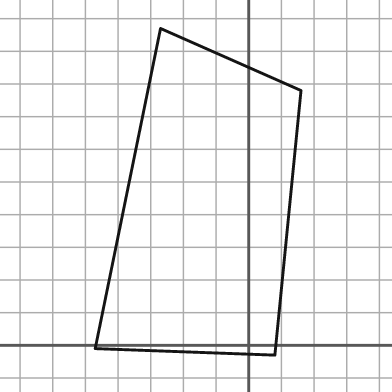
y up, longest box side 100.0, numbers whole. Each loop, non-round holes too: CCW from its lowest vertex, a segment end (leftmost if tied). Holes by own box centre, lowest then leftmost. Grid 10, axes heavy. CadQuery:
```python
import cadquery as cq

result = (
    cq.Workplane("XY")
    .moveTo(8.0, -3.0)
    .lineTo(16.0, 78.0)
    .lineTo(-27.0, 97.0)
    .lineTo(-47.0, -1.0)
    .close()
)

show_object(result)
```